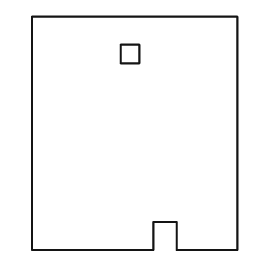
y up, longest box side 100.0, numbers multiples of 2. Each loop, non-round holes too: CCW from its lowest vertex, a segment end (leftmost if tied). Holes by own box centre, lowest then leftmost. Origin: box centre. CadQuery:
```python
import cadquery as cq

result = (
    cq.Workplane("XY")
    .moveTo(-44.0, -50.0)
    .lineTo(8.0, -50.0)
    .lineTo(8.0, -38.0)
    .lineTo(18.0, -38.0)
    .lineTo(18.0, -50.0)
    .lineTo(44.0, -50.0)
    .lineTo(44.0, 50.0)
    .lineTo(-44.0, 50.0)
    .close()
    .moveTo(-6.0, 30.0)
    .lineTo(2.0, 30.0)
    .lineTo(2.0, 38.0)
    .lineTo(-6.0, 38.0)
    .close()
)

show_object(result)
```